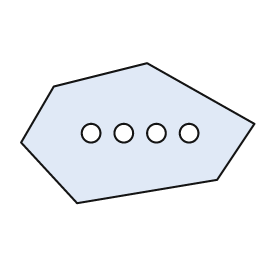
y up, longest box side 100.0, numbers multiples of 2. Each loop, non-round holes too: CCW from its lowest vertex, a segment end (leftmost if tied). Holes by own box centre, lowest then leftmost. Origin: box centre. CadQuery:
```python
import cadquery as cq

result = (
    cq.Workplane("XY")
    .moveTo(-26.0, -30.0)
    .lineTo(34.0, -20.0)
    .lineTo(50.0, 4.0)
    .lineTo(4.0, 30.0)
    .lineTo(-36.0, 20.0)
    .lineTo(-50.0, -4.0)
    .close()
    .moveTo(-20.0, 0.0)
    .circle(4.0)
    .moveTo(-6.0, 0.0)
    .circle(4.0)
    .moveTo(8.0, 0.0)
    .circle(4.0)
    .moveTo(22.0, 0.0)
    .circle(4.0)
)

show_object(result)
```